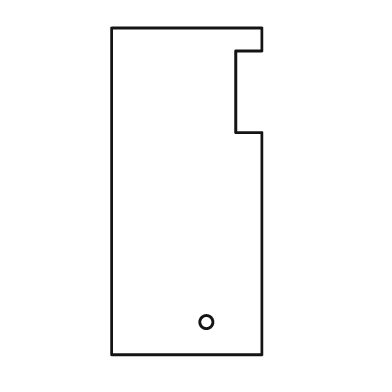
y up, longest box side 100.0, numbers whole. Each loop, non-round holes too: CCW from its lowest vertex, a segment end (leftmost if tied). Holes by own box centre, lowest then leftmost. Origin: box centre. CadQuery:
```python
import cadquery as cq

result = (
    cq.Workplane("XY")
    .moveTo(-23.0, -50.0)
    .lineTo(23.0, -50.0)
    .lineTo(23.0, 18.0)
    .lineTo(15.0, 18.0)
    .lineTo(15.0, 43.0)
    .lineTo(23.0, 43.0)
    .lineTo(23.0, 50.0)
    .lineTo(-23.0, 50.0)
    .close()
    .moveTo(6.0, -40.0)
    .circle(2.0)
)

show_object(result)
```